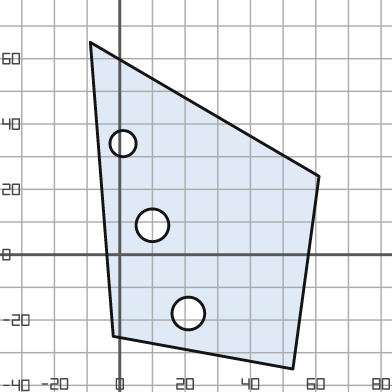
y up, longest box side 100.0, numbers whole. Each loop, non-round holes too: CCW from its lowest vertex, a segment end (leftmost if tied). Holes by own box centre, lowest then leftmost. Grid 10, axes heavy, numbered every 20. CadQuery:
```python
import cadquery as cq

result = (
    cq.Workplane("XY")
    .moveTo(53.0, -35.0)
    .lineTo(61.0, 24.0)
    .lineTo(-9.0, 65.0)
    .lineTo(-2.0, -25.0)
    .close()
    .moveTo(21.0, -18.0)
    .circle(5.0)
    .moveTo(10.0, 9.0)
    .circle(5.0)
    .moveTo(1.0, 34.0)
    .circle(4.0)
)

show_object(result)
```